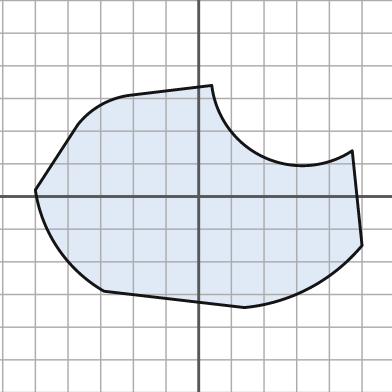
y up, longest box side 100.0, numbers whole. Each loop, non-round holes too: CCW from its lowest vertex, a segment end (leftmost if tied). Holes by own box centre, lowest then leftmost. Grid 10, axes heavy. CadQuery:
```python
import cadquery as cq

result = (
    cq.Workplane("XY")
    .moveTo(14.0, -34.0)
    .threePointArc((34.0, -28.0), (50.0, -15.0))
    .lineTo(47.0, 14.0)
    .threePointArc((20.0, 12.0), (4.0, 34.0))
    .lineTo(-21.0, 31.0)
    .threePointArc((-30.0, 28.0), (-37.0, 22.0))
    .lineTo(-50.0, 2.0)
    .threePointArc((-43.0, -16.0), (-29.0, -29.0))
    .close()
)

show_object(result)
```